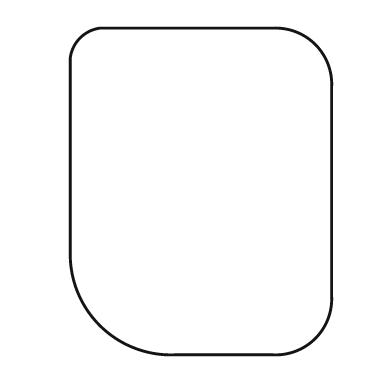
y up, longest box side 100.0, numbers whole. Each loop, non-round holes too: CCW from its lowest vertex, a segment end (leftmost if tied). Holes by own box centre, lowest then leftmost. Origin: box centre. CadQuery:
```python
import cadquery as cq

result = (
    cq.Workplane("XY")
    .moveTo(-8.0, -50.0)
    .lineTo(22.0, -50.0)
    .threePointArc((35.0, -45.0), (40.0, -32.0))
    .lineTo(40.0, 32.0)
    .threePointArc((35.0, 45.0), (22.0, 50.0))
    .lineTo(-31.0, 50.0)
    .threePointArc((-37.0, 47.0), (-40.0, 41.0))
    .lineTo(-40.0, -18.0)
    .threePointArc((-31.0, -41.0), (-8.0, -50.0))
    .close()
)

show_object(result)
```